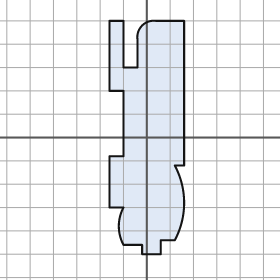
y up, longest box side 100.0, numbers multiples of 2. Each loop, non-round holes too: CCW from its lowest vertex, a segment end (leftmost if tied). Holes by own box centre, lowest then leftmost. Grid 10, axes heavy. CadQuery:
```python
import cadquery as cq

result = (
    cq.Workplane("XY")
    .moveTo(-2.0, -50.0)
    .lineTo(6.0, -50.0)
    .lineTo(6.0, -44.0)
    .lineTo(12.0, -44.0)
    .threePointArc((16.0, -28.0), (12.0, -12.0))
    .lineTo(16.0, -12.0)
    .lineTo(16.0, 50.0)
    .lineTo(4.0, 50.0)
    .threePointArc((-2.0, 48.0), (-4.0, 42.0))
    .lineTo(-4.0, 30.0)
    .lineTo(-10.0, 30.0)
    .lineTo(-10.0, 50.0)
    .lineTo(-16.0, 50.0)
    .lineTo(-16.0, 20.0)
    .lineTo(-10.0, 20.0)
    .lineTo(-10.0, -8.0)
    .lineTo(-16.0, -8.0)
    .lineTo(-16.0, -30.0)
    .lineTo(-10.0, -30.0)
    .threePointArc((-12.0, -38.0), (-10.0, -46.0))
    .lineTo(-2.0, -46.0)
    .close()
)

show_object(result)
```